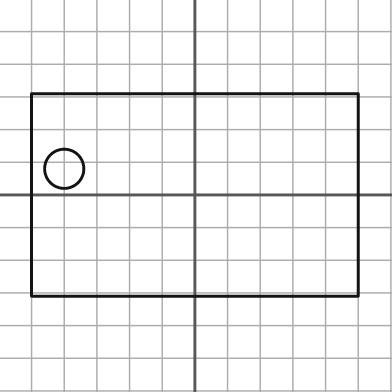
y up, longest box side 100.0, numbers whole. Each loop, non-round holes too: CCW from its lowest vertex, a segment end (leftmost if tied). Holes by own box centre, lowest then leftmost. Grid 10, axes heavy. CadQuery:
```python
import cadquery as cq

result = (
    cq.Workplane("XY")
    .moveTo(-50.0, -31.0)
    .lineTo(50.0, -31.0)
    .lineTo(50.0, 31.0)
    .lineTo(-50.0, 31.0)
    .close()
    .moveTo(-40.0, 8.0)
    .circle(6.0)
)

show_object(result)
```